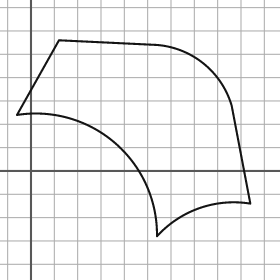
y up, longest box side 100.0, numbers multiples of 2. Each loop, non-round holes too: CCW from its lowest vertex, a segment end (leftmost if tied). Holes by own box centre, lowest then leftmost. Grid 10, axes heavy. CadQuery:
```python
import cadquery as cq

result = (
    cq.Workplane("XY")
    .moveTo(54.0, -28.0)
    .threePointArc((72.0, -16.0), (94.0, -14.0))
    .lineTo(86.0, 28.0)
    .threePointArc((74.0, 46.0), (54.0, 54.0))
    .lineTo(12.0, 56.0)
    .lineTo(-6.0, 24.0)
    .threePointArc((36.0, 12.0), (54.0, -28.0))
    .close()
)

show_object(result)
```